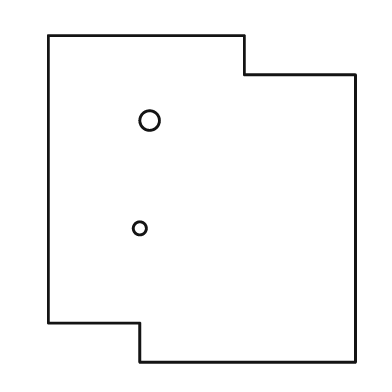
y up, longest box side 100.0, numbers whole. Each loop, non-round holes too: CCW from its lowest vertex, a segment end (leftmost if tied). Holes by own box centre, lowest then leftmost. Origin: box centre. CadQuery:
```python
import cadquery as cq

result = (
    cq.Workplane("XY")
    .moveTo(-19.0, -50.0)
    .lineTo(47.0, -50.0)
    .lineTo(47.0, 38.0)
    .lineTo(13.0, 38.0)
    .lineTo(13.0, 50.0)
    .lineTo(-47.0, 50.0)
    .lineTo(-47.0, -38.0)
    .lineTo(-19.0, -38.0)
    .close()
    .moveTo(-19.0, -9.0)
    .circle(2.0)
    .moveTo(-16.0, 24.0)
    .circle(3.0)
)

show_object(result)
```